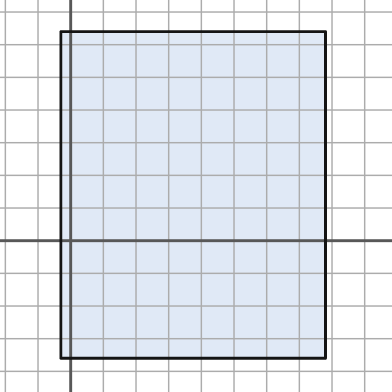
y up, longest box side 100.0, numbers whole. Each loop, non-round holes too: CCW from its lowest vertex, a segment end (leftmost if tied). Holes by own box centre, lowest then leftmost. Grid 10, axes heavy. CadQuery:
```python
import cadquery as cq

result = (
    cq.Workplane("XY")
    .moveTo(-3.0, -36.0)
    .lineTo(78.0, -36.0)
    .lineTo(78.0, 64.0)
    .lineTo(-3.0, 64.0)
    .close()
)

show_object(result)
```